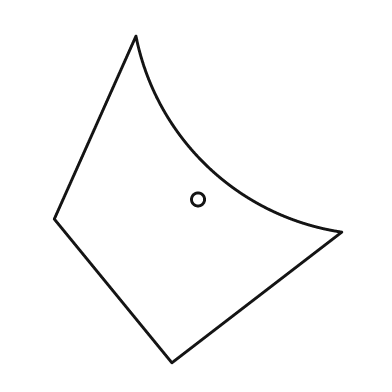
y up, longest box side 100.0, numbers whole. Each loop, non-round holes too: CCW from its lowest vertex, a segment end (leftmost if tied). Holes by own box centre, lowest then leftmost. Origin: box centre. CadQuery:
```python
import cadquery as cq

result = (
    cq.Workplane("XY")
    .moveTo(-8.0, -50.0)
    .lineTo(44.0, -10.0)
    .threePointArc((3.0, 10.0), (-19.0, 50.0))
    .lineTo(-44.0, -6.0)
    .close()
    .moveTo(0.0, 0.0)
    .circle(2.0)
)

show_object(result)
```